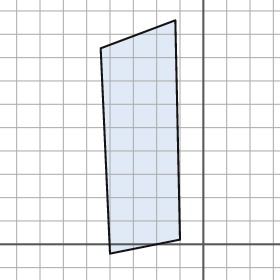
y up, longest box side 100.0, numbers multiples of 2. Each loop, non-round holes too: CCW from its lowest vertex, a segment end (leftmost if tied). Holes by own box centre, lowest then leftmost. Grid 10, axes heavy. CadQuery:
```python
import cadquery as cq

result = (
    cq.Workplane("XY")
    .moveTo(-40.0, -4.0)
    .lineTo(-10.0, 2.0)
    .lineTo(-12.0, 96.0)
    .lineTo(-44.0, 84.0)
    .close()
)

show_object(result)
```